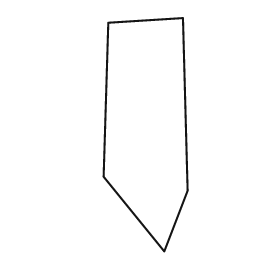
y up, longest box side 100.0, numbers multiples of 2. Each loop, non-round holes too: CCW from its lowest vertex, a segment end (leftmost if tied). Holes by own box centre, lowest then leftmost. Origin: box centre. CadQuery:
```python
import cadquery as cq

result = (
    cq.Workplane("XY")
    .moveTo(8.0, -50.0)
    .lineTo(18.0, -24.0)
    .lineTo(16.0, 50.0)
    .lineTo(-16.0, 48.0)
    .lineTo(-18.0, -18.0)
    .close()
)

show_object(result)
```